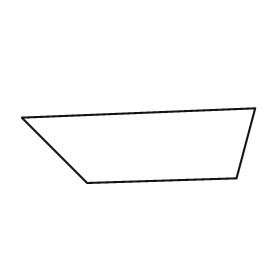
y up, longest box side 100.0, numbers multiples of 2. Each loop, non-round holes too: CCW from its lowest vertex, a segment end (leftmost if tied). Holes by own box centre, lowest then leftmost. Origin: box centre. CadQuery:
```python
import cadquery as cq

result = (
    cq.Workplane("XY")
    .moveTo(-22.0, -16.0)
    .lineTo(42.0, -14.0)
    .lineTo(50.0, 16.0)
    .lineTo(-50.0, 12.0)
    .close()
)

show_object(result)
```